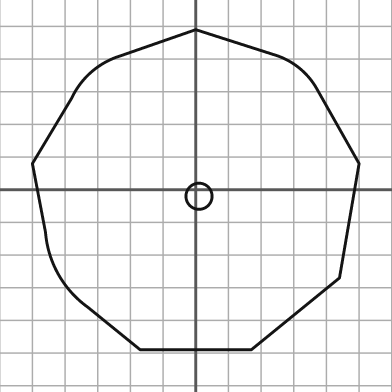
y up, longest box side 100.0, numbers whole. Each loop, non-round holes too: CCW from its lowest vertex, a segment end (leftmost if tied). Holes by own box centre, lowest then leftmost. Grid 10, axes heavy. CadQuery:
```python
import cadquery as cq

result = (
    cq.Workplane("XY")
    .moveTo(-17.0, -49.0)
    .lineTo(17.0, -49.0)
    .lineTo(44.0, -27.0)
    .lineTo(50.0, 8.0)
    .lineTo(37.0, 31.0)
    .threePointArc((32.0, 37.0), (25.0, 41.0))
    .lineTo(0.0, 49.0)
    .lineTo(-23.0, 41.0)
    .threePointArc((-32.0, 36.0), (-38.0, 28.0))
    .lineTo(-50.0, 8.0)
    .lineTo(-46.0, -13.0)
    .threePointArc((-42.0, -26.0), (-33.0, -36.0))
    .close()
    .moveTo(1.0, -2.0)
    .circle(4.0)
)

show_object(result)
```